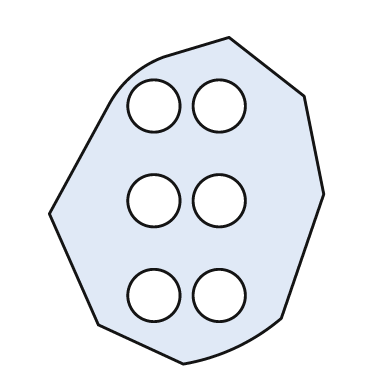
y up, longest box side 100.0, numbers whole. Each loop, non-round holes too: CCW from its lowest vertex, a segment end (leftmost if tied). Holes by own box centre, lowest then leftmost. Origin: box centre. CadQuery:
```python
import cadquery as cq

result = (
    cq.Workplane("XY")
    .moveTo(-1.0, -50.0)
    .threePointArc((15.0, -45.0), (29.0, -36.0))
    .lineTo(42.0, 2.0)
    .lineTo(36.0, 32.0)
    .lineTo(13.0, 50.0)
    .lineTo(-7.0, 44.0)
    .threePointArc((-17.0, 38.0), (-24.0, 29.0))
    .lineTo(-42.0, -4.0)
    .lineTo(-27.0, -38.0)
    .close()
    .moveTo(-10.0, -29.0)
    .circle(8.0)
    .moveTo(10.0, -29.0)
    .circle(8.0)
    .moveTo(-10.0, 0.0)
    .circle(8.0)
    .moveTo(10.0, 0.0)
    .circle(8.0)
    .moveTo(-10.0, 29.0)
    .circle(8.0)
    .moveTo(10.0, 29.0)
    .circle(8.0)
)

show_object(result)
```